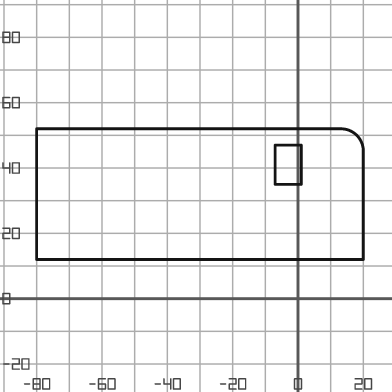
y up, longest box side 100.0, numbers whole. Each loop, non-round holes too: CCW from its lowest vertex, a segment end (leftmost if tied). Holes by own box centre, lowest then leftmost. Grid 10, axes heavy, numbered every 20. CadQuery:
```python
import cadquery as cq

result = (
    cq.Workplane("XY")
    .moveTo(-80.0, 12.0)
    .lineTo(20.0, 12.0)
    .lineTo(20.0, 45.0)
    .threePointArc((18.0, 50.0), (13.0, 52.0))
    .lineTo(-80.0, 52.0)
    .close()
    .moveTo(-7.0, 35.0)
    .lineTo(1.0, 35.0)
    .lineTo(1.0, 47.0)
    .lineTo(-7.0, 47.0)
    .close()
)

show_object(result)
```